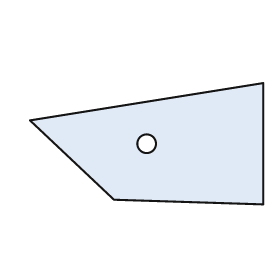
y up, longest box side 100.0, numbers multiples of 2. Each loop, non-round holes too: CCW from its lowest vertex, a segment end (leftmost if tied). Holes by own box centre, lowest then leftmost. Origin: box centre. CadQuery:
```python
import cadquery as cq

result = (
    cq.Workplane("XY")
    .moveTo(50.0, -26.0)
    .lineTo(50.0, 26.0)
    .lineTo(-50.0, 10.0)
    .lineTo(-14.0, -24.0)
    .close()
    .moveTo(0.0, 0.0)
    .circle(4.0)
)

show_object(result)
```